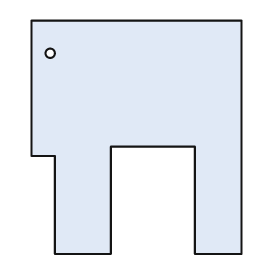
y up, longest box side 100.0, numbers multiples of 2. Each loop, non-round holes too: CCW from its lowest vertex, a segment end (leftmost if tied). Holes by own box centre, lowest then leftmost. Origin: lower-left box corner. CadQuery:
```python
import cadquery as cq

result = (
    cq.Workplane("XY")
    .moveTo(10.0, 0.0)
    .lineTo(34.0, 0.0)
    .lineTo(34.0, 46.0)
    .lineTo(70.0, 46.0)
    .lineTo(70.0, 0.0)
    .lineTo(90.0, 0.0)
    .lineTo(90.0, 100.0)
    .lineTo(0.0, 100.0)
    .lineTo(0.0, 42.0)
    .lineTo(10.0, 42.0)
    .close()
    .moveTo(8.0, 86.0)
    .circle(2.0)
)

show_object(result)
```